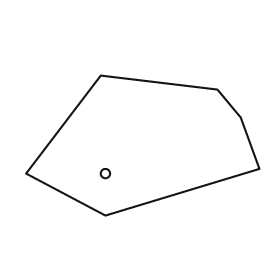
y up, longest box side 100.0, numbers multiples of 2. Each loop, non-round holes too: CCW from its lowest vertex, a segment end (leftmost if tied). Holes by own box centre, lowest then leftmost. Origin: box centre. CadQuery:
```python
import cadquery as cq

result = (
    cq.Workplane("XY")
    .moveTo(-16.0, -30.0)
    .lineTo(50.0, -10.0)
    .lineTo(42.0, 12.0)
    .lineTo(32.0, 24.0)
    .lineTo(-18.0, 30.0)
    .lineTo(-50.0, -12.0)
    .close()
    .moveTo(-16.0, -12.0)
    .circle(2.0)
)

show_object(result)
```